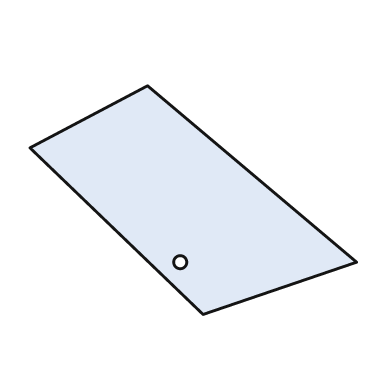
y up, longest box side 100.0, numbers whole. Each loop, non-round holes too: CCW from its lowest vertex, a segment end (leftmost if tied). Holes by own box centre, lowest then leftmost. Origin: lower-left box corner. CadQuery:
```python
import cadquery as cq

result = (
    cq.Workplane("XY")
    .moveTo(53.0, 0.0)
    .lineTo(100.0, 16.0)
    .lineTo(36.0, 70.0)
    .lineTo(0.0, 51.0)
    .close()
    .moveTo(46.0, 16.0)
    .circle(2.0)
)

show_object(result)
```